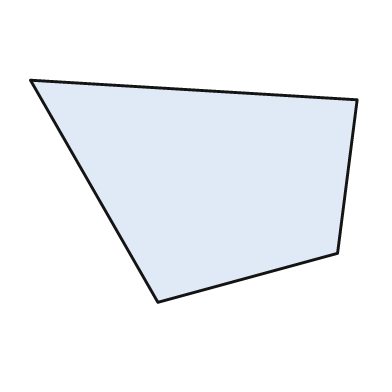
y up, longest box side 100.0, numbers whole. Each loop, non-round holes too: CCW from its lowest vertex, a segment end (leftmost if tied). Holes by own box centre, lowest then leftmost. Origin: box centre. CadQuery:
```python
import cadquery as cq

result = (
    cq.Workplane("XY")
    .moveTo(-11.0, -34.0)
    .lineTo(44.0, -19.0)
    .lineTo(50.0, 28.0)
    .lineTo(-50.0, 34.0)
    .close()
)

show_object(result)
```